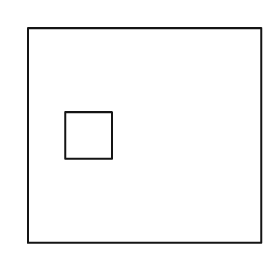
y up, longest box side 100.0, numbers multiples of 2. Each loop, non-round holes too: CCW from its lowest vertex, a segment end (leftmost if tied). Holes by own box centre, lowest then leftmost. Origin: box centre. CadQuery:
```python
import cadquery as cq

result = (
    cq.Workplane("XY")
    .moveTo(-50.0, -46.0)
    .lineTo(50.0, -46.0)
    .lineTo(50.0, 46.0)
    .lineTo(-50.0, 46.0)
    .close()
    .moveTo(-34.0, -10.0)
    .lineTo(-14.0, -10.0)
    .lineTo(-14.0, 10.0)
    .lineTo(-34.0, 10.0)
    .close()
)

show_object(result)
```